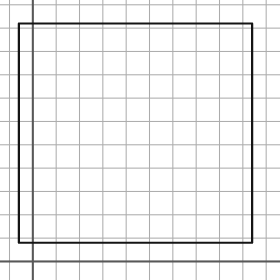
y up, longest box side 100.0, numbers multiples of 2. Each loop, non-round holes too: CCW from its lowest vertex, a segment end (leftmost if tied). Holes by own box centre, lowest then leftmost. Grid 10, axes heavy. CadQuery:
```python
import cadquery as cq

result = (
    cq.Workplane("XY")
    .moveTo(-6.0, 8.0)
    .lineTo(94.0, 8.0)
    .lineTo(94.0, 102.0)
    .lineTo(-6.0, 102.0)
    .close()
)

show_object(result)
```